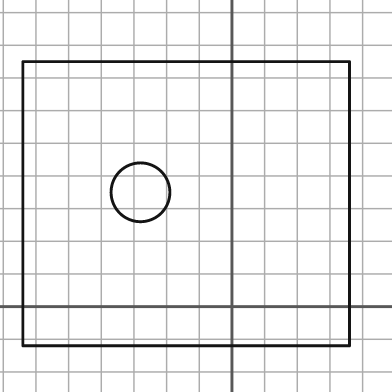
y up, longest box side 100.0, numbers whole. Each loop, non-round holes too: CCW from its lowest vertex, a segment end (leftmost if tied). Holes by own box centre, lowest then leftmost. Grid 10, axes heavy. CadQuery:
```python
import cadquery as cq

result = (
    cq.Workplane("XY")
    .moveTo(-64.0, -12.0)
    .lineTo(36.0, -12.0)
    .lineTo(36.0, 75.0)
    .lineTo(-64.0, 75.0)
    .close()
    .moveTo(-28.0, 35.0)
    .circle(9.0)
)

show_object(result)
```